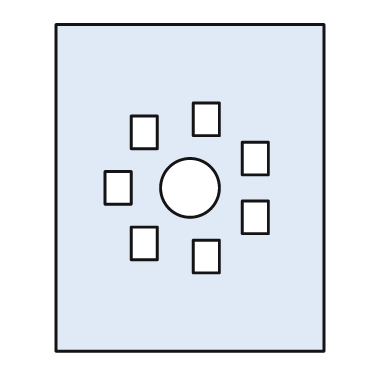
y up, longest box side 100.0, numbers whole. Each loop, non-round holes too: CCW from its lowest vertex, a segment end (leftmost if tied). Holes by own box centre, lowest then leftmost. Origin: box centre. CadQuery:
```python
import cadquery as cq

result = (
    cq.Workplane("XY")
    .moveTo(-41.0, -50.0)
    .lineTo(41.0, -50.0)
    .lineTo(41.0, 50.0)
    .lineTo(-41.0, 50.0)
    .close()
    .moveTo(1.0, -26.0)
    .lineTo(9.0, -26.0)
    .lineTo(9.0, -16.0)
    .lineTo(1.0, -16.0)
    .close()
    .moveTo(-18.0, -22.0)
    .lineTo(-10.0, -22.0)
    .lineTo(-10.0, -12.0)
    .lineTo(-18.0, -12.0)
    .close()
    .moveTo(16.0, -14.0)
    .lineTo(24.0, -14.0)
    .lineTo(24.0, -4.0)
    .lineTo(16.0, -4.0)
    .close()
    .moveTo(-26.0, -5.0)
    .lineTo(-18.0, -5.0)
    .lineTo(-18.0, 5.0)
    .lineTo(-26.0, 5.0)
    .close()
    .moveTo(0.0, 0.0)
    .circle(9.0)
    .moveTo(16.0, 4.0)
    .lineTo(24.0, 4.0)
    .lineTo(24.0, 14.0)
    .lineTo(16.0, 14.0)
    .close()
    .moveTo(-18.0, 12.0)
    .lineTo(-10.0, 12.0)
    .lineTo(-10.0, 22.0)
    .lineTo(-18.0, 22.0)
    .close()
    .moveTo(1.0, 16.0)
    .lineTo(9.0, 16.0)
    .lineTo(9.0, 26.0)
    .lineTo(1.0, 26.0)
    .close()
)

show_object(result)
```